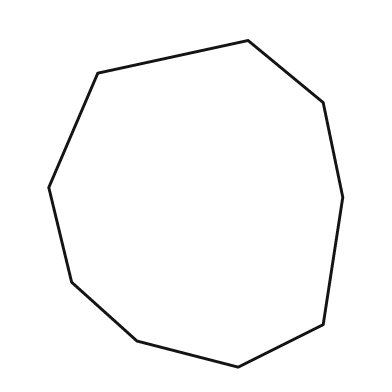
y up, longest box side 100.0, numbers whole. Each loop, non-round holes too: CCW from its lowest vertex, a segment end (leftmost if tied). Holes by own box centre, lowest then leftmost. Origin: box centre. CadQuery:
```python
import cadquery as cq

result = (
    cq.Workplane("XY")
    .moveTo(13.0, -50.0)
    .lineTo(39.0, -37.0)
    .lineTo(45.0, 2.0)
    .lineTo(39.0, 31.0)
    .lineTo(16.0, 50.0)
    .lineTo(-30.0, 40.0)
    .lineTo(-45.0, 5.0)
    .lineTo(-38.0, -24.0)
    .lineTo(-18.0, -42.0)
    .close()
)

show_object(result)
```